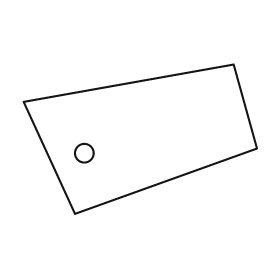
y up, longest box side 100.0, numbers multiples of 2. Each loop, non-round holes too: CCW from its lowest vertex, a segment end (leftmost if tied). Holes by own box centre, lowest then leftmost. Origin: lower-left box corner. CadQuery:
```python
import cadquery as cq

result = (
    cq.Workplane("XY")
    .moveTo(22.0, 0.0)
    .lineTo(100.0, 28.0)
    .lineTo(90.0, 64.0)
    .lineTo(0.0, 48.0)
    .close()
    .moveTo(26.0, 26.0)
    .circle(4.0)
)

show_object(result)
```